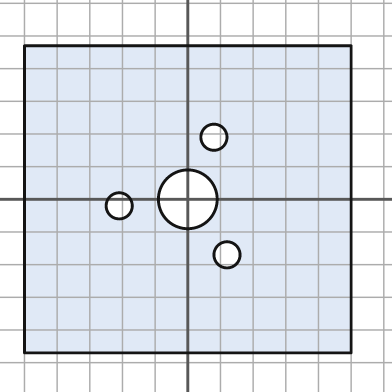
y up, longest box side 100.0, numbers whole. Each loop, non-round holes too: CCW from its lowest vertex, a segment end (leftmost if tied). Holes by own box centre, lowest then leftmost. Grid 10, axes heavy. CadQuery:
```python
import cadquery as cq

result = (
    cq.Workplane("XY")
    .moveTo(-50.0, -47.0)
    .lineTo(50.0, -47.0)
    .lineTo(50.0, 47.0)
    .lineTo(-50.0, 47.0)
    .close()
    .moveTo(12.0, -17.0)
    .circle(4.0)
    .moveTo(-21.0, -2.0)
    .circle(4.0)
    .moveTo(0.0, 0.0)
    .circle(9.0)
    .moveTo(8.0, 19.0)
    .circle(4.0)
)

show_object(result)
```